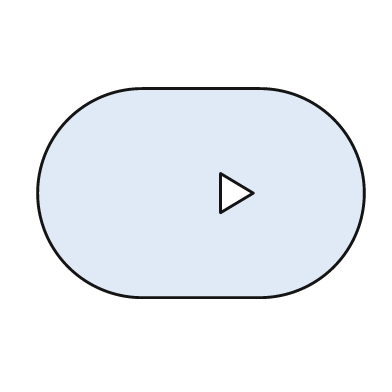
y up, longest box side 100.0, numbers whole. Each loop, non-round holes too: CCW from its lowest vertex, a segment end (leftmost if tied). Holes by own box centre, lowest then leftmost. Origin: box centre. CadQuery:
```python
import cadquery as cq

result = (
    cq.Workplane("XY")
    .moveTo(-18.0, -32.0)
    .lineTo(18.0, -32.0)
    .threePointArc((50.0, 0.0), (18.0, 32.0))
    .lineTo(-18.0, 32.0)
    .threePointArc((-50.0, 0.0), (-18.0, -32.0))
    .close()
    .moveTo(6.0, -6.0)
    .lineTo(16.0, 0.0)
    .lineTo(6.0, 6.0)
    .close()
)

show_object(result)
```